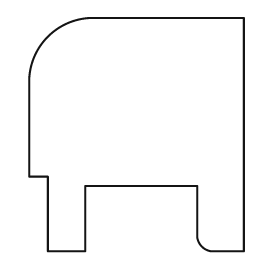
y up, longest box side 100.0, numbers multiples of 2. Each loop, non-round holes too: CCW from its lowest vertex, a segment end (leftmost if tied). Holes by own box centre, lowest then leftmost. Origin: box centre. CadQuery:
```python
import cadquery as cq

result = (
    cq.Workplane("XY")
    .moveTo(-38.0, -50.0)
    .lineTo(-22.0, -50.0)
    .lineTo(-22.0, -22.0)
    .lineTo(26.0, -22.0)
    .lineTo(26.0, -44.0)
    .threePointArc((28.0, -48.0), (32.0, -50.0))
    .lineTo(46.0, -50.0)
    .lineTo(46.0, 50.0)
    .lineTo(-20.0, 50.0)
    .threePointArc((-38.0, 42.0), (-46.0, 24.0))
    .lineTo(-46.0, -18.0)
    .lineTo(-38.0, -18.0)
    .close()
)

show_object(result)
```